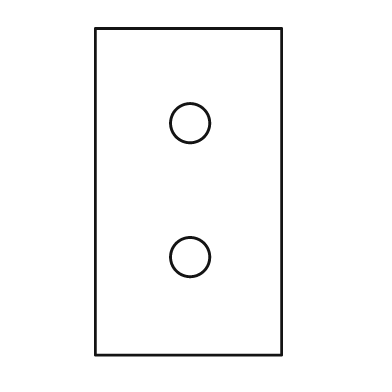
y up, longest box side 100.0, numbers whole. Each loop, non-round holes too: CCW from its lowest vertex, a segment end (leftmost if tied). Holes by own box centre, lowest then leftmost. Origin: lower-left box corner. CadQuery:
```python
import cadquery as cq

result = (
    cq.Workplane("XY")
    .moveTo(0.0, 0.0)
    .lineTo(57.0, 0.0)
    .lineTo(57.0, 100.0)
    .lineTo(0.0, 100.0)
    .close()
    .moveTo(29.0, 30.0)
    .circle(6.0)
    .moveTo(29.0, 71.0)
    .circle(6.0)
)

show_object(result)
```